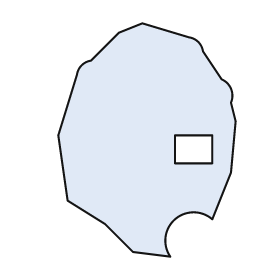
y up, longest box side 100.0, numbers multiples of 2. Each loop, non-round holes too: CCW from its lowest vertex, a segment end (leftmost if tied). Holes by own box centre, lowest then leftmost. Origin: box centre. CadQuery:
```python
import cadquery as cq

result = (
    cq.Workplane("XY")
    .moveTo(10.0, -50.0)
    .threePointArc((12.0, -34.0), (28.0, -34.0))
    .lineTo(36.0, -14.0)
    .lineTo(38.0, 8.0)
    .lineTo(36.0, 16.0)
    .threePointArc((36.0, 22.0), (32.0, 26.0))
    .lineTo(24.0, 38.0)
    .threePointArc((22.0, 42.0), (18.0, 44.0))
    .lineTo(-2.0, 50.0)
    .lineTo(-12.0, 46.0)
    .lineTo(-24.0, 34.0)
    .threePointArc((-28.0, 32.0), (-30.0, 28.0))
    .lineTo(-38.0, 2.0)
    .lineTo(-34.0, -26.0)
    .lineTo(-18.0, -36.0)
    .lineTo(-6.0, -48.0)
    .close()
    .moveTo(12.0, -10.0)
    .lineTo(28.0, -10.0)
    .lineTo(28.0, 2.0)
    .lineTo(12.0, 2.0)
    .close()
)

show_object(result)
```